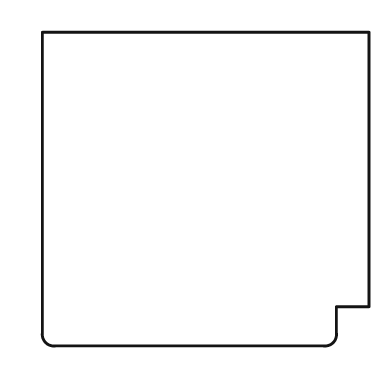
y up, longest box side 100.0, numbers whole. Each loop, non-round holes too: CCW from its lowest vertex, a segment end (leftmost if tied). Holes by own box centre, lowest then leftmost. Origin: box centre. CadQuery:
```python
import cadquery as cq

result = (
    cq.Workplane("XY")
    .moveTo(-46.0, -48.0)
    .lineTo(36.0, -48.0)
    .threePointArc((39.0, -47.0), (40.0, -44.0))
    .lineTo(40.0, -36.0)
    .lineTo(50.0, -36.0)
    .lineTo(50.0, 48.0)
    .lineTo(-50.0, 48.0)
    .lineTo(-50.0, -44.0)
    .threePointArc((-49.0, -47.0), (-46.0, -48.0))
    .close()
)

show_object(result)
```